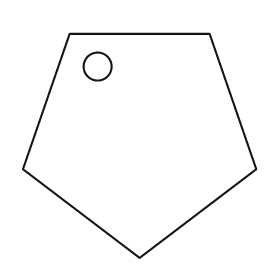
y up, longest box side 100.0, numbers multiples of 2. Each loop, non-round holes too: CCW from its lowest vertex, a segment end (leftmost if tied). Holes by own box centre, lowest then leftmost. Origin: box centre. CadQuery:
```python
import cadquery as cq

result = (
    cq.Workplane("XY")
    .moveTo(0.0, -48.0)
    .lineTo(50.0, -10.0)
    .lineTo(30.0, 48.0)
    .lineTo(-30.0, 48.0)
    .lineTo(-50.0, -10.0)
    .close()
    .moveTo(-18.0, 34.0)
    .circle(6.0)
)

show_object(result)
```